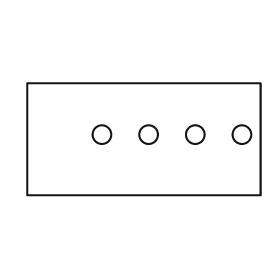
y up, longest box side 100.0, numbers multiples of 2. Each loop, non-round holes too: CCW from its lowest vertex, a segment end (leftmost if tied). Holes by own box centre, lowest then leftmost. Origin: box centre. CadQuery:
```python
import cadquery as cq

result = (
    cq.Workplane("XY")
    .moveTo(-50.0, -24.0)
    .lineTo(50.0, -24.0)
    .lineTo(50.0, 24.0)
    .lineTo(-50.0, 24.0)
    .close()
    .moveTo(-18.0, 2.0)
    .circle(4.0)
    .moveTo(2.0, 2.0)
    .circle(4.0)
    .moveTo(22.0, 2.0)
    .circle(4.0)
    .moveTo(42.0, 2.0)
    .circle(4.0)
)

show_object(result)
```